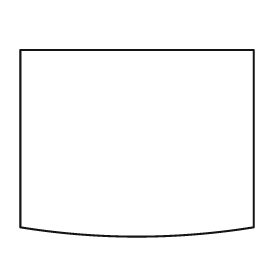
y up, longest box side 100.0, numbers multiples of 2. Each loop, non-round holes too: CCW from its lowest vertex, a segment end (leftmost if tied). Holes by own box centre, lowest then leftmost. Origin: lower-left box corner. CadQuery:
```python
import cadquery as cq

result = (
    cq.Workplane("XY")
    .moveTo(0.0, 4.0)
    .threePointArc((50.0, 0.0), (100.0, 4.0))
    .lineTo(100.0, 80.0)
    .lineTo(0.0, 80.0)
    .close()
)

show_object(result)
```